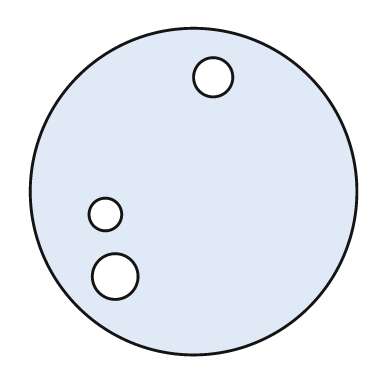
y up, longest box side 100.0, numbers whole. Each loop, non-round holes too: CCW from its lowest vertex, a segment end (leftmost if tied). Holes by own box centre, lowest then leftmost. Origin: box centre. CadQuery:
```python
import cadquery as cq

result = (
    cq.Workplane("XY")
    .moveTo(0.0, 0.0)
    .circle(50.0)
    .moveTo(-24.0, -26.0)
    .circle(7.0)
    .moveTo(-27.0, -7.0)
    .circle(5.0)
    .moveTo(6.0, 35.0)
    .circle(6.0)
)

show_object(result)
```